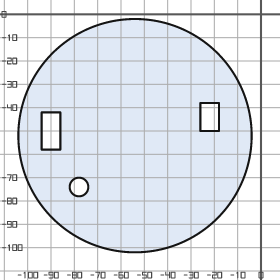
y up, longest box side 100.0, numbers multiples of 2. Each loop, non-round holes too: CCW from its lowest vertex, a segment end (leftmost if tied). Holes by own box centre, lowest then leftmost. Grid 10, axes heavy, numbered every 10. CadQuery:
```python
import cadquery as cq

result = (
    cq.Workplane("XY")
    .moveTo(-54.0, -52.0)
    .circle(50.0)
    .moveTo(-78.0, -74.0)
    .circle(4.0)
    .moveTo(-94.0, -58.0)
    .lineTo(-86.0, -58.0)
    .lineTo(-86.0, -42.0)
    .lineTo(-94.0, -42.0)
    .close()
    .moveTo(-26.0, -50.0)
    .lineTo(-18.0, -50.0)
    .lineTo(-18.0, -38.0)
    .lineTo(-26.0, -38.0)
    .close()
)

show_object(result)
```